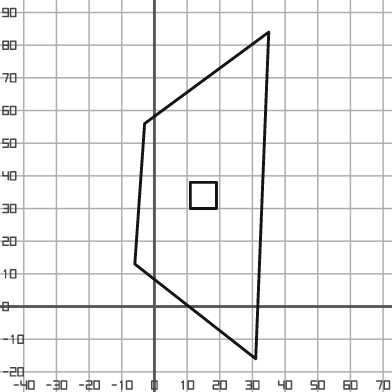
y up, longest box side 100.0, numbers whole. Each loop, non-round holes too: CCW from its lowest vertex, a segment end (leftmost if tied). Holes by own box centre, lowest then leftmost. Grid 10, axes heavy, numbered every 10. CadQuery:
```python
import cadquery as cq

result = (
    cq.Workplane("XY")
    .moveTo(31.0, -16.0)
    .lineTo(35.0, 84.0)
    .lineTo(-3.0, 56.0)
    .lineTo(-6.0, 13.0)
    .close()
    .moveTo(11.0, 30.0)
    .lineTo(19.0, 30.0)
    .lineTo(19.0, 38.0)
    .lineTo(11.0, 38.0)
    .close()
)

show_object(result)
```